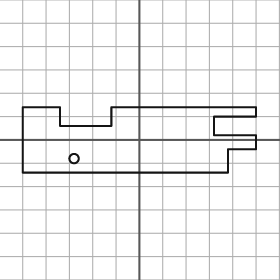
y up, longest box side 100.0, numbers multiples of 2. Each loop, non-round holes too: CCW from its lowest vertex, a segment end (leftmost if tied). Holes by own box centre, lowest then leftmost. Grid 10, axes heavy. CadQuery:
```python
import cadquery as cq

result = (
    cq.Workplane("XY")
    .moveTo(-50.0, -14.0)
    .lineTo(38.0, -14.0)
    .lineTo(38.0, -4.0)
    .lineTo(50.0, -4.0)
    .lineTo(50.0, 2.0)
    .lineTo(32.0, 2.0)
    .lineTo(32.0, 10.0)
    .lineTo(50.0, 10.0)
    .lineTo(50.0, 14.0)
    .lineTo(-12.0, 14.0)
    .lineTo(-12.0, 6.0)
    .lineTo(-34.0, 6.0)
    .lineTo(-34.0, 14.0)
    .lineTo(-50.0, 14.0)
    .close()
    .moveTo(-28.0, -8.0)
    .circle(2.0)
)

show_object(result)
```